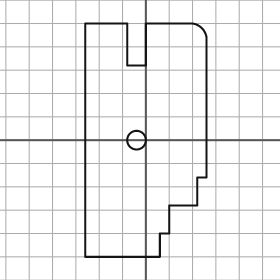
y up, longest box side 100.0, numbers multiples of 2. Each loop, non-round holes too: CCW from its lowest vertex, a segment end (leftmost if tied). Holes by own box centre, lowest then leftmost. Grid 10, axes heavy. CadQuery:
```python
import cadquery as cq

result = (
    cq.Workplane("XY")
    .moveTo(-26.0, -50.0)
    .lineTo(6.0, -50.0)
    .lineTo(6.0, -40.0)
    .lineTo(10.0, -40.0)
    .lineTo(10.0, -28.0)
    .lineTo(22.0, -28.0)
    .lineTo(22.0, -16.0)
    .lineTo(26.0, -16.0)
    .lineTo(26.0, 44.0)
    .threePointArc((24.0, 48.0), (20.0, 50.0))
    .lineTo(0.0, 50.0)
    .lineTo(0.0, 32.0)
    .lineTo(-8.0, 32.0)
    .lineTo(-8.0, 50.0)
    .lineTo(-26.0, 50.0)
    .close()
    .moveTo(-4.0, 0.0)
    .circle(4.0)
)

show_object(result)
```